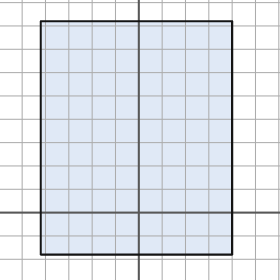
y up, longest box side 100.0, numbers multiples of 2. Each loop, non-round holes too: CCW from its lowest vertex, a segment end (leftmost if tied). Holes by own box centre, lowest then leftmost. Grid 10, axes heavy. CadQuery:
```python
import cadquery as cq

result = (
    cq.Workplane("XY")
    .moveTo(-42.0, -18.0)
    .lineTo(40.0, -18.0)
    .lineTo(40.0, 82.0)
    .lineTo(-42.0, 82.0)
    .close()
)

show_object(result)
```